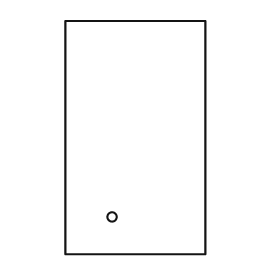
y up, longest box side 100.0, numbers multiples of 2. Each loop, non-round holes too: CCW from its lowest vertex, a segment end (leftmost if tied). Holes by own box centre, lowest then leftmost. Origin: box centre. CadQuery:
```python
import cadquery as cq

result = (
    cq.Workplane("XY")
    .moveTo(-30.0, -50.0)
    .lineTo(30.0, -50.0)
    .lineTo(30.0, 50.0)
    .lineTo(-30.0, 50.0)
    .close()
    .moveTo(-10.0, -34.0)
    .circle(2.0)
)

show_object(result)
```